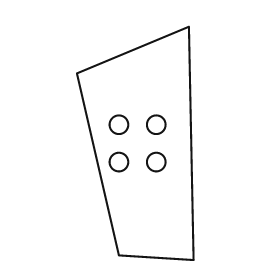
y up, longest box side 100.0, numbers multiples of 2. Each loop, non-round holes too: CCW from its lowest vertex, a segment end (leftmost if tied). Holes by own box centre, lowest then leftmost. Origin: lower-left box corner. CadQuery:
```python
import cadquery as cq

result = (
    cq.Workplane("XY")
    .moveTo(50.0, 0.0)
    .lineTo(48.0, 100.0)
    .lineTo(0.0, 80.0)
    .lineTo(18.0, 2.0)
    .close()
    .moveTo(18.0, 42.0)
    .circle(4.0)
    .moveTo(34.0, 42.0)
    .circle(4.0)
    .moveTo(18.0, 58.0)
    .circle(4.0)
    .moveTo(34.0, 58.0)
    .circle(4.0)
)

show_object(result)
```